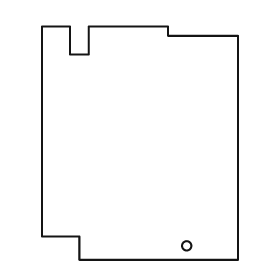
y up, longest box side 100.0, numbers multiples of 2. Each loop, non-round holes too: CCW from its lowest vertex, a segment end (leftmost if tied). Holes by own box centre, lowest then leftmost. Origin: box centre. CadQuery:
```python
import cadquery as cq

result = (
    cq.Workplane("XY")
    .moveTo(-26.0, -50.0)
    .lineTo(42.0, -50.0)
    .lineTo(42.0, 46.0)
    .lineTo(12.0, 46.0)
    .lineTo(12.0, 50.0)
    .lineTo(-22.0, 50.0)
    .lineTo(-22.0, 38.0)
    .lineTo(-30.0, 38.0)
    .lineTo(-30.0, 50.0)
    .lineTo(-42.0, 50.0)
    .lineTo(-42.0, -40.0)
    .lineTo(-26.0, -40.0)
    .close()
    .moveTo(20.0, -44.0)
    .circle(2.0)
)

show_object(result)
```